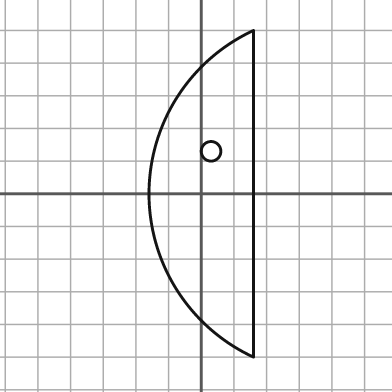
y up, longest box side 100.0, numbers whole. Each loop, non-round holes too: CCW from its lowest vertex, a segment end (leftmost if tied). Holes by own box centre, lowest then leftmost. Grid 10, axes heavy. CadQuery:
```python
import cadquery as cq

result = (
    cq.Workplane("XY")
    .moveTo(16.0, -50.0)
    .lineTo(16.0, 50.0)
    .threePointArc((-16.0, 0.0), (16.0, -50.0))
    .close()
    .moveTo(3.0, 13.0)
    .circle(3.0)
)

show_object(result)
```